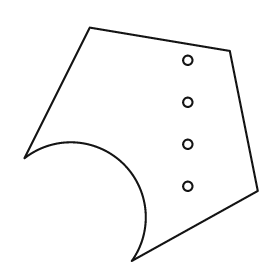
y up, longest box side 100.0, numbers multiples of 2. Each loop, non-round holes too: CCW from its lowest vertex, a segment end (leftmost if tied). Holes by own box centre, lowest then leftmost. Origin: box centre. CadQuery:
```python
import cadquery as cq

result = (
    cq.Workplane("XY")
    .moveTo(-4.0, -50.0)
    .lineTo(50.0, -20.0)
    .lineTo(38.0, 40.0)
    .lineTo(-22.0, 50.0)
    .lineTo(-50.0, -6.0)
    .threePointArc((-8.0, -8.0), (-4.0, -50.0))
    .close()
    .moveTo(20.0, -18.0)
    .circle(2.0)
    .moveTo(20.0, 0.0)
    .circle(2.0)
    .moveTo(20.0, 18.0)
    .circle(2.0)
    .moveTo(20.0, 36.0)
    .circle(2.0)
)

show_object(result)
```